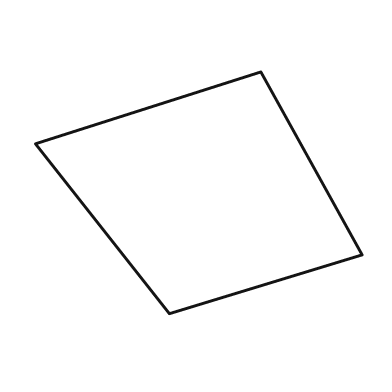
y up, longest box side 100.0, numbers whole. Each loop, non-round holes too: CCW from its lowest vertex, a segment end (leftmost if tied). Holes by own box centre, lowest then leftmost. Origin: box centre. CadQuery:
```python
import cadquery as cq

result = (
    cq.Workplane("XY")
    .moveTo(-9.0, -37.0)
    .lineTo(50.0, -19.0)
    .lineTo(19.0, 37.0)
    .lineTo(-50.0, 15.0)
    .close()
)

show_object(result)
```